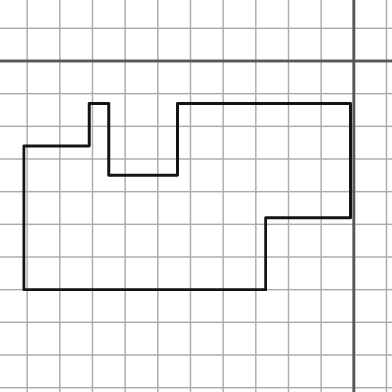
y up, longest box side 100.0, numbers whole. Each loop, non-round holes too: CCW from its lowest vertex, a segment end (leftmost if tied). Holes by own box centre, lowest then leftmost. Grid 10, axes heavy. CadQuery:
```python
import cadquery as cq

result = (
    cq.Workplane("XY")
    .moveTo(-101.0, -70.0)
    .lineTo(-27.0, -70.0)
    .lineTo(-27.0, -48.0)
    .lineTo(-1.0, -48.0)
    .lineTo(-1.0, -13.0)
    .lineTo(-54.0, -13.0)
    .lineTo(-54.0, -35.0)
    .lineTo(-75.0, -35.0)
    .lineTo(-75.0, -13.0)
    .lineTo(-81.0, -13.0)
    .lineTo(-81.0, -26.0)
    .lineTo(-101.0, -26.0)
    .close()
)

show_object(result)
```